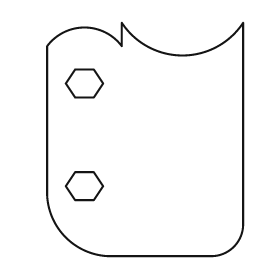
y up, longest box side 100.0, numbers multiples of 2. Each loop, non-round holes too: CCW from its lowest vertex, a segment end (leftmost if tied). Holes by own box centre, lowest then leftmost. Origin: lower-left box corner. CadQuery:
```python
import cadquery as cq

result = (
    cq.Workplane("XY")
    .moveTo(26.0, 0.0)
    .lineTo(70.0, 0.0)
    .threePointArc((80.0, 4.0), (84.0, 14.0))
    .lineTo(84.0, 100.0)
    .threePointArc((58.0, 86.0), (32.0, 100.0))
    .lineTo(32.0, 90.0)
    .threePointArc((16.0, 98.0), (0.0, 90.0))
    .lineTo(0.0, 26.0)
    .threePointArc((8.0, 8.0), (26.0, 0.0))
    .close()
    .moveTo(12.0, 24.0)
    .lineTo(20.0, 24.0)
    .lineTo(24.0, 30.0)
    .lineTo(20.0, 36.0)
    .lineTo(12.0, 36.0)
    .lineTo(8.0, 30.0)
    .close()
    .moveTo(12.0, 68.0)
    .lineTo(20.0, 68.0)
    .lineTo(24.0, 74.0)
    .lineTo(20.0, 80.0)
    .lineTo(12.0, 80.0)
    .lineTo(8.0, 74.0)
    .close()
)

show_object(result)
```